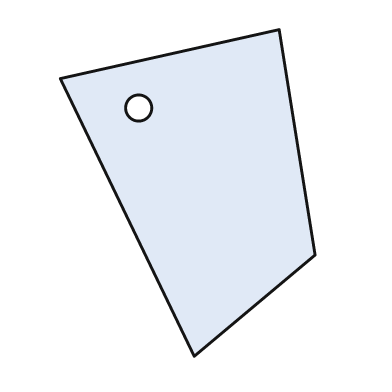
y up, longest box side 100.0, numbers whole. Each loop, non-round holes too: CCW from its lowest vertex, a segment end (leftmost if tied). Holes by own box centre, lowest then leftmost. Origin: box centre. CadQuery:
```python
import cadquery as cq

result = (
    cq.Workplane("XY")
    .moveTo(2.0, -50.0)
    .lineTo(39.0, -19.0)
    .lineTo(28.0, 50.0)
    .lineTo(-39.0, 35.0)
    .close()
    .moveTo(-15.0, 26.0)
    .circle(4.0)
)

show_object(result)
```